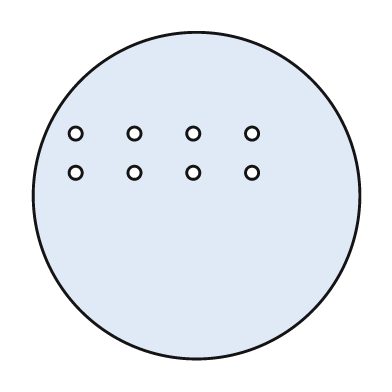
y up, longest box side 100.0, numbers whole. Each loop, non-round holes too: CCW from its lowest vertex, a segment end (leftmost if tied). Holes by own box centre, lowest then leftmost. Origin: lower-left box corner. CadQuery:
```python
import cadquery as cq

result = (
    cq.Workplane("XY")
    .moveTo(50.0, 50.0)
    .circle(50.0)
    .moveTo(13.0, 57.0)
    .circle(2.0)
    .moveTo(31.0, 57.0)
    .circle(2.0)
    .moveTo(49.0, 57.0)
    .circle(2.0)
    .moveTo(67.0, 57.0)
    .circle(2.0)
    .moveTo(13.0, 69.0)
    .circle(2.0)
    .moveTo(31.0, 69.0)
    .circle(2.0)
    .moveTo(49.0, 69.0)
    .circle(2.0)
    .moveTo(67.0, 69.0)
    .circle(2.0)
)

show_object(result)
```